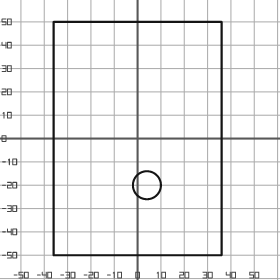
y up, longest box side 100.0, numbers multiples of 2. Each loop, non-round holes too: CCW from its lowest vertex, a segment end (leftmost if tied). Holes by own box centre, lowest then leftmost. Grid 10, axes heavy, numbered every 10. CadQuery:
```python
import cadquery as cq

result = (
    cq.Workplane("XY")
    .moveTo(-36.0, -50.0)
    .lineTo(36.0, -50.0)
    .lineTo(36.0, 50.0)
    .lineTo(-36.0, 50.0)
    .close()
    .moveTo(4.0, -20.0)
    .circle(6.0)
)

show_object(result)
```